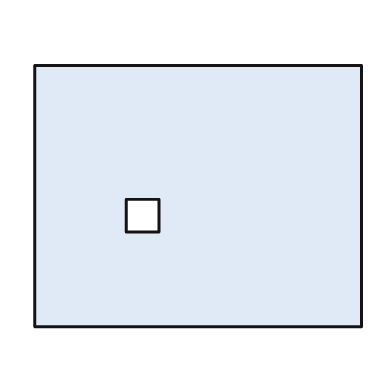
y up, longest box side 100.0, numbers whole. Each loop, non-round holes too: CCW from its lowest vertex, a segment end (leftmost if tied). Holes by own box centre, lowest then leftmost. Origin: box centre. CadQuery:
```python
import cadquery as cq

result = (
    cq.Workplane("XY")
    .moveTo(-50.0, -40.0)
    .lineTo(50.0, -40.0)
    .lineTo(50.0, 40.0)
    .lineTo(-50.0, 40.0)
    .close()
    .moveTo(-22.0, -11.0)
    .lineTo(-12.0, -11.0)
    .lineTo(-12.0, -1.0)
    .lineTo(-22.0, -1.0)
    .close()
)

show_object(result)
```